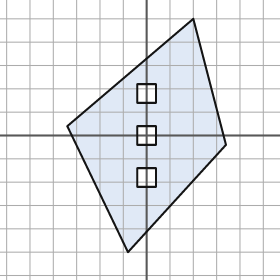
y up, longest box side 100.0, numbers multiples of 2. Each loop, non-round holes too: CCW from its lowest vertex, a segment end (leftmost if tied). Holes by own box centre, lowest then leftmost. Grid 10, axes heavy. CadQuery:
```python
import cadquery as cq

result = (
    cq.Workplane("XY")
    .moveTo(-8.0, -50.0)
    .lineTo(34.0, -4.0)
    .lineTo(20.0, 50.0)
    .lineTo(-34.0, 4.0)
    .close()
    .moveTo(-4.0, -22.0)
    .lineTo(4.0, -22.0)
    .lineTo(4.0, -14.0)
    .lineTo(-4.0, -14.0)
    .close()
    .moveTo(-4.0, -4.0)
    .lineTo(4.0, -4.0)
    .lineTo(4.0, 4.0)
    .lineTo(-4.0, 4.0)
    .close()
    .moveTo(-4.0, 14.0)
    .lineTo(4.0, 14.0)
    .lineTo(4.0, 22.0)
    .lineTo(-4.0, 22.0)
    .close()
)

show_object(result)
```